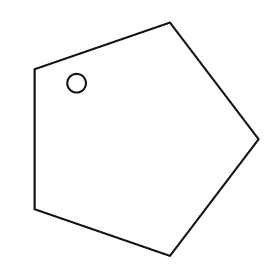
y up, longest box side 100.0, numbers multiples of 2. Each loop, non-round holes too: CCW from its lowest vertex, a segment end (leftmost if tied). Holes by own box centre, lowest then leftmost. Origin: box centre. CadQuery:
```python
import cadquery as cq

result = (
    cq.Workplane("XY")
    .moveTo(10.0, -50.0)
    .lineTo(48.0, 0.0)
    .lineTo(10.0, 50.0)
    .lineTo(-48.0, 30.0)
    .lineTo(-48.0, -30.0)
    .close()
    .moveTo(-30.0, 24.0)
    .circle(4.0)
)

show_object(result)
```